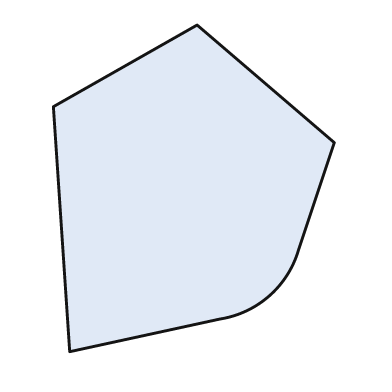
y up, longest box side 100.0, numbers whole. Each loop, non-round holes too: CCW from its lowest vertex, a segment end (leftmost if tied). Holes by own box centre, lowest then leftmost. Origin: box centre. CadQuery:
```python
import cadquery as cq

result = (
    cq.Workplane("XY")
    .moveTo(-38.0, -50.0)
    .lineTo(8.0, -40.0)
    .threePointArc((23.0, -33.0), (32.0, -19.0))
    .lineTo(43.0, 14.0)
    .lineTo(1.0, 50.0)
    .lineTo(-43.0, 25.0)
    .close()
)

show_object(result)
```